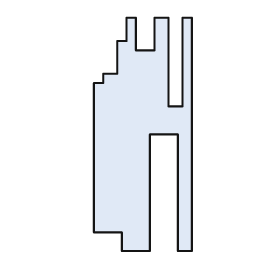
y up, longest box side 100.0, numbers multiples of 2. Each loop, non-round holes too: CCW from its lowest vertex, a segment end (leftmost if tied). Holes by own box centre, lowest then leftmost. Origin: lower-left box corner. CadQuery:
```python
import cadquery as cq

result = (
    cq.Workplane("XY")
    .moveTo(12.0, 0.0)
    .lineTo(24.0, 0.0)
    .lineTo(24.0, 50.0)
    .lineTo(36.0, 50.0)
    .lineTo(36.0, 0.0)
    .lineTo(42.0, 0.0)
    .lineTo(42.0, 100.0)
    .lineTo(38.0, 100.0)
    .lineTo(38.0, 62.0)
    .lineTo(32.0, 62.0)
    .lineTo(32.0, 100.0)
    .lineTo(26.0, 100.0)
    .lineTo(26.0, 86.0)
    .lineTo(18.0, 86.0)
    .lineTo(18.0, 100.0)
    .lineTo(14.0, 100.0)
    .lineTo(14.0, 90.0)
    .lineTo(10.0, 90.0)
    .lineTo(10.0, 76.0)
    .lineTo(4.0, 76.0)
    .lineTo(4.0, 72.0)
    .lineTo(0.0, 72.0)
    .lineTo(0.0, 8.0)
    .lineTo(12.0, 8.0)
    .close()
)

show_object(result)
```